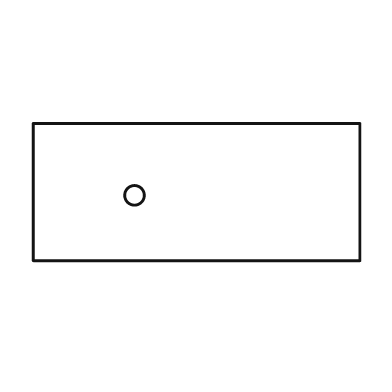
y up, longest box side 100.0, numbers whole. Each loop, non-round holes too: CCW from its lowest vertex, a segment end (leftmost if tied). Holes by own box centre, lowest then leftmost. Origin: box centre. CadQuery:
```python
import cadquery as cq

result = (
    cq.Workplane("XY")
    .moveTo(-50.0, -21.0)
    .lineTo(50.0, -21.0)
    .lineTo(50.0, 21.0)
    .lineTo(-50.0, 21.0)
    .close()
    .moveTo(-19.0, -1.0)
    .circle(3.0)
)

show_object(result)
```